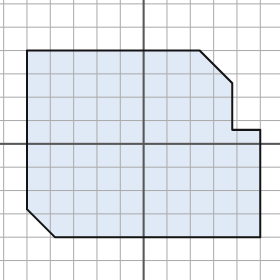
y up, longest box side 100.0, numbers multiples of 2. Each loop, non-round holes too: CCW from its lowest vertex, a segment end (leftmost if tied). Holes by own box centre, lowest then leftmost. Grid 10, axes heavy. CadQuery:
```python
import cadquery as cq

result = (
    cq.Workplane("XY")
    .moveTo(-38.0, -40.0)
    .lineTo(50.0, -40.0)
    .lineTo(50.0, 6.0)
    .lineTo(38.0, 6.0)
    .lineTo(38.0, 26.0)
    .lineTo(24.0, 40.0)
    .lineTo(-50.0, 40.0)
    .lineTo(-50.0, -28.0)
    .close()
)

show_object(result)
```